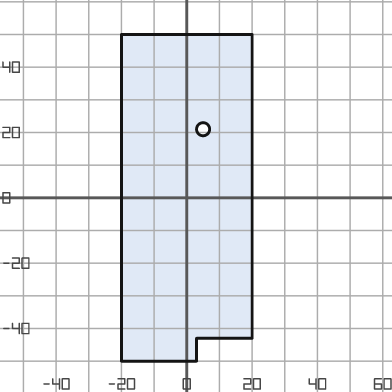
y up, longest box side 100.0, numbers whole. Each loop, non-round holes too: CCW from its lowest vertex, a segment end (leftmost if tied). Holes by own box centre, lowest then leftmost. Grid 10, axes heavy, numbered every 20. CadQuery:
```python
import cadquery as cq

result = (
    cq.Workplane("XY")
    .moveTo(-20.0, -50.0)
    .lineTo(3.0, -50.0)
    .lineTo(3.0, -43.0)
    .lineTo(20.0, -43.0)
    .lineTo(20.0, 50.0)
    .lineTo(-20.0, 50.0)
    .close()
    .moveTo(5.0, 21.0)
    .circle(2.0)
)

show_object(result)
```